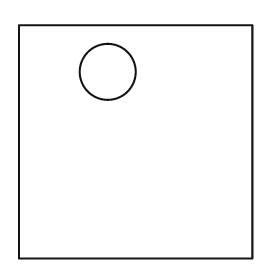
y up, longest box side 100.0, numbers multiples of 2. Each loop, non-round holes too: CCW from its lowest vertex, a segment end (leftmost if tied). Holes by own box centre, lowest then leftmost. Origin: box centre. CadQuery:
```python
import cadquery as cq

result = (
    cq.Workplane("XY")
    .moveTo(-50.0, -50.0)
    .lineTo(50.0, -50.0)
    .lineTo(50.0, 50.0)
    .lineTo(-50.0, 50.0)
    .close()
    .moveTo(-12.0, 30.0)
    .circle(12.0)
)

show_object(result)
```